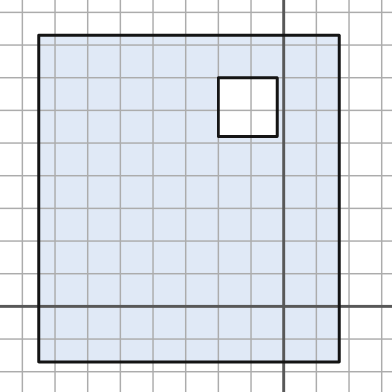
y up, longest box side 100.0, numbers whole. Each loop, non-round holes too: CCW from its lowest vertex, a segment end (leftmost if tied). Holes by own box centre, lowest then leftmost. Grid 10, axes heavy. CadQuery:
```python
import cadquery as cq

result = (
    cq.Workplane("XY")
    .moveTo(-75.0, -17.0)
    .lineTo(17.0, -17.0)
    .lineTo(17.0, 83.0)
    .lineTo(-75.0, 83.0)
    .close()
    .moveTo(-20.0, 52.0)
    .lineTo(-2.0, 52.0)
    .lineTo(-2.0, 70.0)
    .lineTo(-20.0, 70.0)
    .close()
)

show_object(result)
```